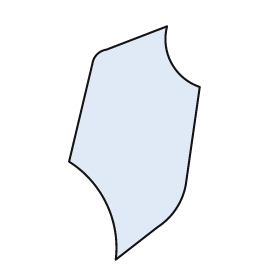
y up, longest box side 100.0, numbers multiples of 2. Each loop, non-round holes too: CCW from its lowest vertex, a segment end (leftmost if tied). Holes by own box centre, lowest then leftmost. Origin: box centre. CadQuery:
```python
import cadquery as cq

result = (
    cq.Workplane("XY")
    .moveTo(-8.0, -50.0)
    .lineTo(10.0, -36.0)
    .threePointArc((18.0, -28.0), (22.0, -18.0))
    .lineTo(28.0, 24.0)
    .threePointArc((16.0, 34.0), (14.0, 50.0))
    .lineTo(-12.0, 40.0)
    .threePointArc((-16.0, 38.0), (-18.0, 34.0))
    .lineTo(-28.0, -8.0)
    .threePointArc((-12.0, -26.0), (-8.0, -50.0))
    .close()
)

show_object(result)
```